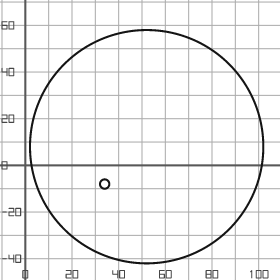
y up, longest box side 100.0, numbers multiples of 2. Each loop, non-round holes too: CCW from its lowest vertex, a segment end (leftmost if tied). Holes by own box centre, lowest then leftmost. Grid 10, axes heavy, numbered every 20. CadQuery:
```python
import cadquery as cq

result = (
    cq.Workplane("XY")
    .moveTo(52.0, 8.0)
    .circle(50.0)
    .moveTo(34.0, -8.0)
    .circle(2.0)
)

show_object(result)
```